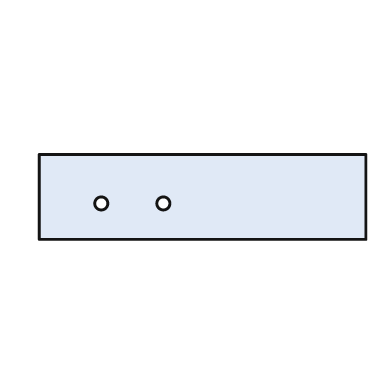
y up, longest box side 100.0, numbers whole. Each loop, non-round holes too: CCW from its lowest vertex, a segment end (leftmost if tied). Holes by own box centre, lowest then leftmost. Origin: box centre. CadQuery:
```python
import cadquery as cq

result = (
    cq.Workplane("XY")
    .moveTo(-50.0, -13.0)
    .lineTo(50.0, -13.0)
    .lineTo(50.0, 13.0)
    .lineTo(-50.0, 13.0)
    .close()
    .moveTo(-31.0, -2.0)
    .circle(2.0)
    .moveTo(-12.0, -2.0)
    .circle(2.0)
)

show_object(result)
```